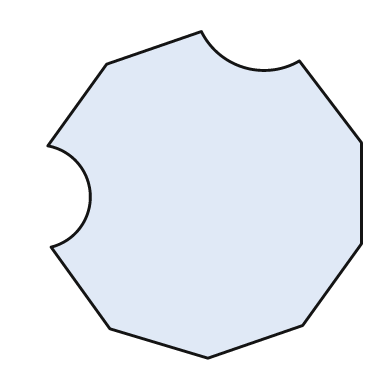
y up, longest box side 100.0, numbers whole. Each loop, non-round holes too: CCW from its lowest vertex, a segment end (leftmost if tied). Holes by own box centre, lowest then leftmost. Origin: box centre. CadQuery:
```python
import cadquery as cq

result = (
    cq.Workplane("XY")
    .moveTo(1.0, -50.0)
    .lineTo(30.0, -40.0)
    .lineTo(48.0, -15.0)
    .lineTo(48.0, 16.0)
    .lineTo(29.0, 41.0)
    .threePointArc((12.0, 39.0), (-1.0, 50.0))
    .lineTo(-30.0, 40.0)
    .lineTo(-48.0, 15.0)
    .threePointArc((-35.0, 0.0), (-47.0, -16.0))
    .lineTo(-29.0, -41.0)
    .close()
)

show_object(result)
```